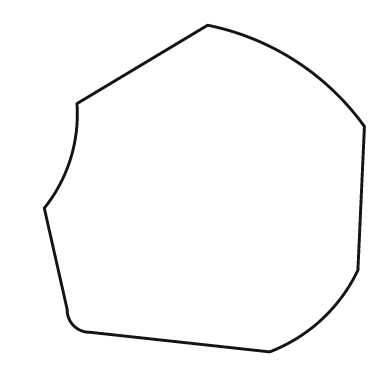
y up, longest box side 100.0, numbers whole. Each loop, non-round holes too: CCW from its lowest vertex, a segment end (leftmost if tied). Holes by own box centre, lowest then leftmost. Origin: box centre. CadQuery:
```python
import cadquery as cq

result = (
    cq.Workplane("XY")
    .moveTo(20.0, -50.0)
    .threePointArc((36.0, -40.0), (47.0, -25.0))
    .lineTo(49.0, 19.0)
    .threePointArc((28.0, 39.0), (1.0, 50.0))
    .lineTo(-39.0, 26.0)
    .threePointArc((-41.0, 9.0), (-49.0, -6.0))
    .lineTo(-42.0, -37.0)
    .threePointArc((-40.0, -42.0), (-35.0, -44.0))
    .close()
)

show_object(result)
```